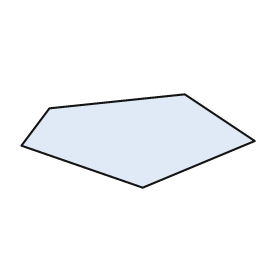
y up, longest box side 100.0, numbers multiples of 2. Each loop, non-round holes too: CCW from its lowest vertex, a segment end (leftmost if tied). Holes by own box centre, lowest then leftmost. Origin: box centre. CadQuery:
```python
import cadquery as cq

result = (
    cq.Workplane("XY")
    .moveTo(2.0, -20.0)
    .lineTo(50.0, 0.0)
    .lineTo(20.0, 20.0)
    .lineTo(-38.0, 14.0)
    .lineTo(-50.0, -2.0)
    .close()
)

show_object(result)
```